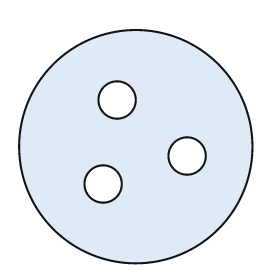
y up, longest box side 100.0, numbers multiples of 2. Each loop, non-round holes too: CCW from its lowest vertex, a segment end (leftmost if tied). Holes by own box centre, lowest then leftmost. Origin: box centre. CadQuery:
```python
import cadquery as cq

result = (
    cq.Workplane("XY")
    .moveTo(0.0, 0.0)
    .circle(50.0)
    .moveTo(-14.0, -16.0)
    .circle(8.0)
    .moveTo(22.0, -4.0)
    .circle(8.0)
    .moveTo(-8.0, 20.0)
    .circle(8.0)
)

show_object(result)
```